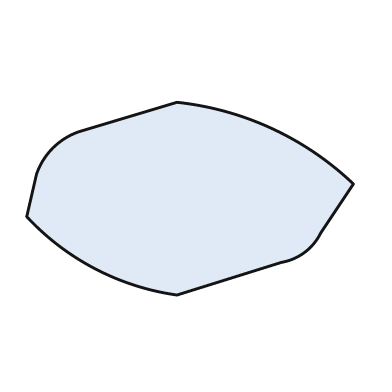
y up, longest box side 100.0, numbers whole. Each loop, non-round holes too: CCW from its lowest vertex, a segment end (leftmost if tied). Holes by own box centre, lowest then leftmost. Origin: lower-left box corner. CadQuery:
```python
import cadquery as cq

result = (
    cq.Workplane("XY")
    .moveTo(46.0, 0.0)
    .lineTo(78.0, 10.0)
    .threePointArc((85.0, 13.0), (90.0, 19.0))
    .lineTo(100.0, 34.0)
    .threePointArc((75.0, 51.0), (46.0, 59.0))
    .lineTo(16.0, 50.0)
    .threePointArc((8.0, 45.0), (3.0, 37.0))
    .lineTo(0.0, 24.0)
    .threePointArc((21.0, 8.0), (46.0, 0.0))
    .close()
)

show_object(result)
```